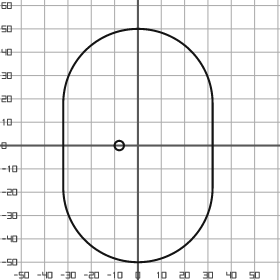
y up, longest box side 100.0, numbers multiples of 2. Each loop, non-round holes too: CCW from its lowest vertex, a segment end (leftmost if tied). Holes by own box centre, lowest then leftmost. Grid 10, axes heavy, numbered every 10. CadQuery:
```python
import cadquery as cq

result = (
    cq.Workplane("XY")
    .moveTo(-32.0, -18.0)
    .threePointArc((0.0, -50.0), (32.0, -18.0))
    .lineTo(32.0, 18.0)
    .threePointArc((0.0, 50.0), (-32.0, 18.0))
    .close()
    .moveTo(-8.0, 0.0)
    .circle(2.0)
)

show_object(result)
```